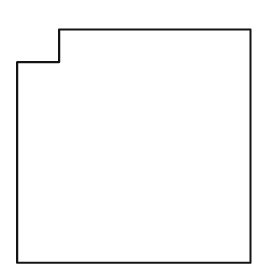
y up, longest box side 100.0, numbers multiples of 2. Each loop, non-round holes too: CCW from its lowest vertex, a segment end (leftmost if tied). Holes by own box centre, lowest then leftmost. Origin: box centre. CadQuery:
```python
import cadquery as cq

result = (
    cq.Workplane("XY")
    .moveTo(-50.0, -50.0)
    .lineTo(50.0, -50.0)
    .lineTo(50.0, 50.0)
    .lineTo(-32.0, 50.0)
    .lineTo(-32.0, 36.0)
    .lineTo(-50.0, 36.0)
    .close()
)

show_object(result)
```